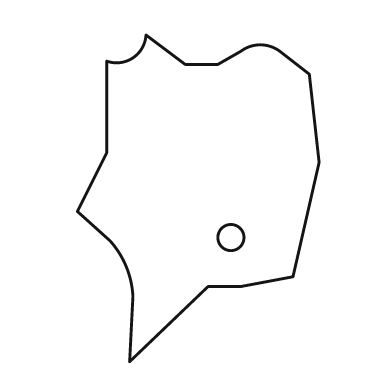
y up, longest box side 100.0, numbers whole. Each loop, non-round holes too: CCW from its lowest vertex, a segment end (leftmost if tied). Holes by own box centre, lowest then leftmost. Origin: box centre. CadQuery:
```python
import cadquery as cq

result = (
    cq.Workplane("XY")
    .moveTo(-21.0, -50.0)
    .lineTo(3.0, -27.0)
    .lineTo(13.0, -27.0)
    .lineTo(29.0, -24.0)
    .lineTo(37.0, 11.0)
    .lineTo(34.0, 38.0)
    .lineTo(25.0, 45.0)
    .threePointArc((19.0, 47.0), (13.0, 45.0))
    .lineTo(6.0, 41.0)
    .lineTo(-4.0, 41.0)
    .lineTo(-16.0, 50.0)
    .threePointArc((-20.0, 43.0), (-28.0, 42.0))
    .lineTo(-28.0, 14.0)
    .lineTo(-37.0, -4.0)
    .lineTo(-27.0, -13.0)
    .threePointArc((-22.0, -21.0), (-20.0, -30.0))
    .close()
    .moveTo(10.0, -12.0)
    .circle(4.0)
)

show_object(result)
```